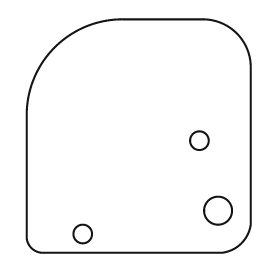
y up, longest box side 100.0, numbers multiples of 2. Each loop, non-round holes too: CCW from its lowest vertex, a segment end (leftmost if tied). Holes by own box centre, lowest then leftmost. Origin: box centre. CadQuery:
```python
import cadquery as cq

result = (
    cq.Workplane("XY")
    .moveTo(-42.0, -50.0)
    .lineTo(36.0, -50.0)
    .threePointArc((44.0, -46.0), (48.0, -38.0))
    .lineTo(48.0, 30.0)
    .threePointArc((42.0, 44.0), (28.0, 50.0))
    .lineTo(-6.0, 50.0)
    .threePointArc((-36.0, 38.0), (-48.0, 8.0))
    .lineTo(-48.0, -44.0)
    .threePointArc((-46.0, -48.0), (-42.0, -50.0))
    .close()
    .moveTo(-24.0, -42.0)
    .circle(4.0)
    .moveTo(34.0, -32.0)
    .circle(6.0)
    .moveTo(26.0, -2.0)
    .circle(4.0)
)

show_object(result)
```